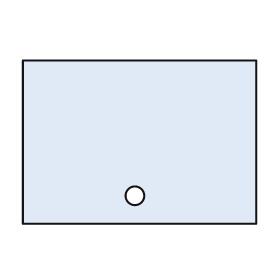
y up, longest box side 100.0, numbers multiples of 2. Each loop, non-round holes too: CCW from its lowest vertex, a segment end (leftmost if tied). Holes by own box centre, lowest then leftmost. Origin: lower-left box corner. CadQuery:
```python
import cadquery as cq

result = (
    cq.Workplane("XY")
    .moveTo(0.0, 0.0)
    .lineTo(100.0, 0.0)
    .lineTo(100.0, 70.0)
    .lineTo(0.0, 70.0)
    .close()
    .moveTo(48.0, 12.0)
    .circle(4.0)
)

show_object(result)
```